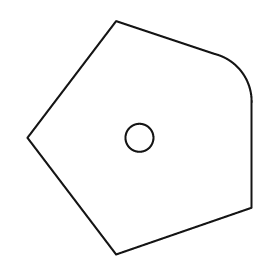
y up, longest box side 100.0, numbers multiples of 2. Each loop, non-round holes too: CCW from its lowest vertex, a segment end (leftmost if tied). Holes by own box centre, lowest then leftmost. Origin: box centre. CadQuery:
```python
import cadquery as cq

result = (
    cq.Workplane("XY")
    .moveTo(-10.0, -50.0)
    .lineTo(48.0, -30.0)
    .lineTo(48.0, 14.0)
    .threePointArc((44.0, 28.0), (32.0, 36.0))
    .lineTo(-10.0, 50.0)
    .lineTo(-48.0, 0.0)
    .close()
    .moveTo(0.0, 0.0)
    .circle(6.0)
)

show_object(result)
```